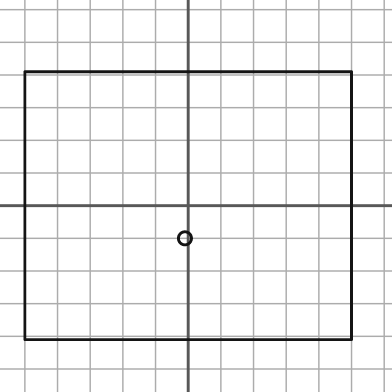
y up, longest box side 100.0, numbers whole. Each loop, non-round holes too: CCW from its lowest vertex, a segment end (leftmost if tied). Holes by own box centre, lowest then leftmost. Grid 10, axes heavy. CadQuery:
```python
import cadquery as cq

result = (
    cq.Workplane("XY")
    .moveTo(-50.0, -41.0)
    .lineTo(50.0, -41.0)
    .lineTo(50.0, 41.0)
    .lineTo(-50.0, 41.0)
    .close()
    .moveTo(-1.0, -10.0)
    .circle(2.0)
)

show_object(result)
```